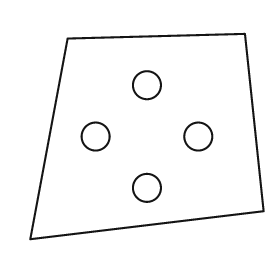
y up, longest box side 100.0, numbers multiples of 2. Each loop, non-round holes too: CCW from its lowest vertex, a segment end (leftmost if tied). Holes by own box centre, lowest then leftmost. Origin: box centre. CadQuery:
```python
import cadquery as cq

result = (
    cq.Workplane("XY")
    .moveTo(-50.0, -44.0)
    .lineTo(50.0, -32.0)
    .lineTo(42.0, 44.0)
    .lineTo(-34.0, 42.0)
    .close()
    .moveTo(0.0, -22.0)
    .circle(6.0)
    .moveTo(-22.0, 0.0)
    .circle(6.0)
    .moveTo(22.0, 0.0)
    .circle(6.0)
    .moveTo(0.0, 22.0)
    .circle(6.0)
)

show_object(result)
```